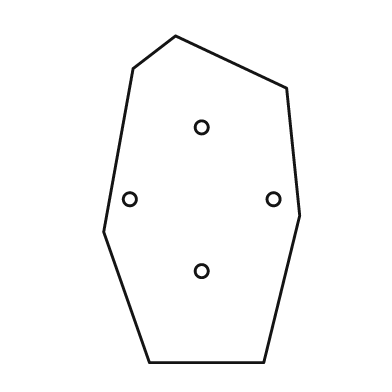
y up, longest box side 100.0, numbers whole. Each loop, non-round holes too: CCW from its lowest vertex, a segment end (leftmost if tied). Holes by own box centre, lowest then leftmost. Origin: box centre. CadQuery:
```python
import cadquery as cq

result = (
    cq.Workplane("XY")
    .moveTo(-16.0, -50.0)
    .lineTo(19.0, -50.0)
    .lineTo(30.0, -5.0)
    .lineTo(26.0, 34.0)
    .lineTo(-8.0, 50.0)
    .lineTo(-21.0, 40.0)
    .lineTo(-30.0, -10.0)
    .close()
    .moveTo(0.0, -22.0)
    .circle(2.0)
    .moveTo(-22.0, 0.0)
    .circle(2.0)
    .moveTo(22.0, 0.0)
    .circle(2.0)
    .moveTo(0.0, 22.0)
    .circle(2.0)
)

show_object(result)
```